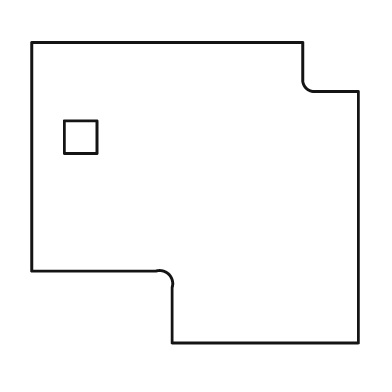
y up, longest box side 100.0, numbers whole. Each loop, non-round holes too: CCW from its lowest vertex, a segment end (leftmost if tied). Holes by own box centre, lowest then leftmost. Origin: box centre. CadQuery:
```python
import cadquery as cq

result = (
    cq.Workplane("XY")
    .moveTo(-7.0, -46.0)
    .lineTo(50.0, -46.0)
    .lineTo(50.0, 31.0)
    .lineTo(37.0, 31.0)
    .threePointArc((34.0, 32.0), (33.0, 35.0))
    .lineTo(33.0, 46.0)
    .lineTo(-50.0, 46.0)
    .lineTo(-50.0, -24.0)
    .lineTo(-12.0, -24.0)
    .threePointArc((-8.0, -25.0), (-7.0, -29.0))
    .close()
    .moveTo(-40.0, 12.0)
    .lineTo(-30.0, 12.0)
    .lineTo(-30.0, 22.0)
    .lineTo(-40.0, 22.0)
    .close()
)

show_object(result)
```